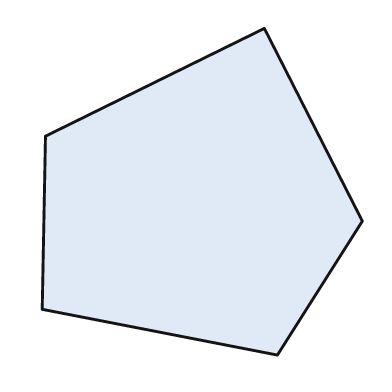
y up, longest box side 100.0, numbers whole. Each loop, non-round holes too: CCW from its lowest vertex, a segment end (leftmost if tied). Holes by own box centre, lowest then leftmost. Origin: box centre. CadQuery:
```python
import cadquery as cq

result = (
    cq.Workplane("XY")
    .moveTo(23.0, -50.0)
    .lineTo(49.0, -9.0)
    .lineTo(19.0, 50.0)
    .lineTo(-48.0, 17.0)
    .lineTo(-49.0, -36.0)
    .close()
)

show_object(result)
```